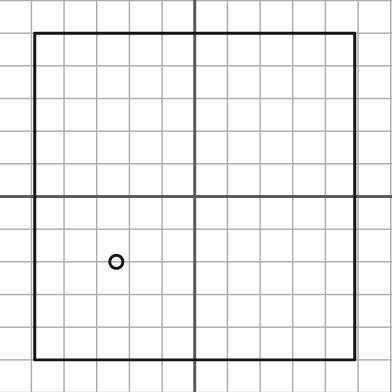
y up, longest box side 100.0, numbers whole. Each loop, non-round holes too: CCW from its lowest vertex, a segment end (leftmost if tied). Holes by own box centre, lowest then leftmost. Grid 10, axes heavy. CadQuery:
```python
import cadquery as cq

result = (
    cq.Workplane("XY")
    .moveTo(-49.0, -50.0)
    .lineTo(49.0, -50.0)
    .lineTo(49.0, 50.0)
    .lineTo(-49.0, 50.0)
    .close()
    .moveTo(-24.0, -20.0)
    .circle(2.0)
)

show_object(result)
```